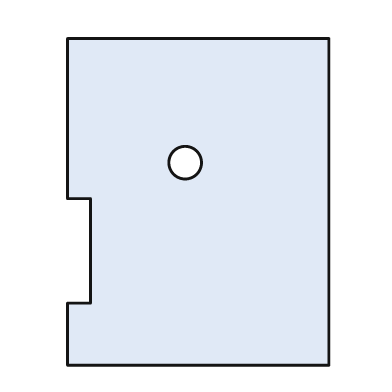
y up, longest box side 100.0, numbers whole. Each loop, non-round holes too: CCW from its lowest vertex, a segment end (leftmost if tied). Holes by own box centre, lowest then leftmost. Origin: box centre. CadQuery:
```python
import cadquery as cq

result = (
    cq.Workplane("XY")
    .moveTo(-40.0, -50.0)
    .lineTo(40.0, -50.0)
    .lineTo(40.0, 50.0)
    .lineTo(-40.0, 50.0)
    .lineTo(-40.0, 1.0)
    .lineTo(-33.0, 1.0)
    .lineTo(-33.0, -31.0)
    .lineTo(-40.0, -31.0)
    .close()
    .moveTo(-4.0, 12.0)
    .circle(5.0)
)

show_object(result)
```